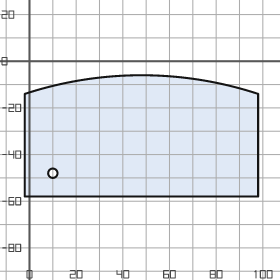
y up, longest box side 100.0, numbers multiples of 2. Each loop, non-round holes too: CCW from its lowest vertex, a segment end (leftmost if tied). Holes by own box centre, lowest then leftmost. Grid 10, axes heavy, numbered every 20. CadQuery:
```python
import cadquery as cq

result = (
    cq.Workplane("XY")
    .moveTo(-2.0, -58.0)
    .lineTo(98.0, -58.0)
    .lineTo(98.0, -14.0)
    .threePointArc((48.0, -6.0), (-2.0, -14.0))
    .close()
    .moveTo(10.0, -48.0)
    .circle(2.0)
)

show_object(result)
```